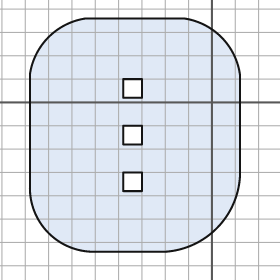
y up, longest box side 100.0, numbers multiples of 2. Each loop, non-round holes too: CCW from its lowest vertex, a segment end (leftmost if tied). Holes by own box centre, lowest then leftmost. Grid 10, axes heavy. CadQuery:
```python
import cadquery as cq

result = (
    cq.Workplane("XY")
    .moveTo(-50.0, -64.0)
    .lineTo(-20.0, -64.0)
    .threePointArc((2.0, -54.0), (12.0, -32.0))
    .lineTo(12.0, 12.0)
    .threePointArc((4.0, 28.0), (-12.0, 36.0))
    .lineTo(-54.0, 36.0)
    .threePointArc((-70.0, 28.0), (-78.0, 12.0))
    .lineTo(-78.0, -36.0)
    .threePointArc((-70.0, -56.0), (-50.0, -64.0))
    .close()
    .moveTo(-38.0, -38.0)
    .lineTo(-30.0, -38.0)
    .lineTo(-30.0, -30.0)
    .lineTo(-38.0, -30.0)
    .close()
    .moveTo(-38.0, -18.0)
    .lineTo(-30.0, -18.0)
    .lineTo(-30.0, -10.0)
    .lineTo(-38.0, -10.0)
    .close()
    .moveTo(-38.0, 2.0)
    .lineTo(-30.0, 2.0)
    .lineTo(-30.0, 10.0)
    .lineTo(-38.0, 10.0)
    .close()
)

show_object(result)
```